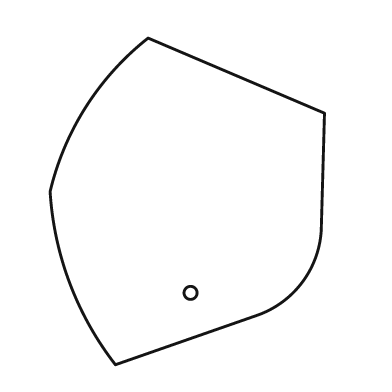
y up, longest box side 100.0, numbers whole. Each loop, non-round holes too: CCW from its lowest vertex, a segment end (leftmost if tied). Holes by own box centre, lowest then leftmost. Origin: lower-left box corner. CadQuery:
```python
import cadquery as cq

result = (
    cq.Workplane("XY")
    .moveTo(20.0, 0.0)
    .lineTo(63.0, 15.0)
    .threePointArc((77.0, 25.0), (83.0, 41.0))
    .lineTo(84.0, 77.0)
    .lineTo(30.0, 100.0)
    .threePointArc((11.0, 79.0), (0.0, 53.0))
    .threePointArc((6.0, 25.0), (20.0, 0.0))
    .close()
    .moveTo(43.0, 22.0)
    .circle(2.0)
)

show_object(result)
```